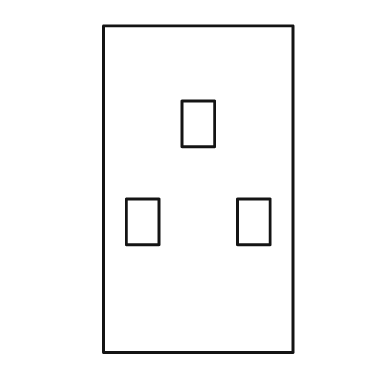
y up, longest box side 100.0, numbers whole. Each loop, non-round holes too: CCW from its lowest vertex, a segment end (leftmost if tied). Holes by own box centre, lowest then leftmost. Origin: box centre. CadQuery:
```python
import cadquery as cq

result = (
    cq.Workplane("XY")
    .moveTo(-29.0, -50.0)
    .lineTo(29.0, -50.0)
    .lineTo(29.0, 50.0)
    .lineTo(-29.0, 50.0)
    .close()
    .moveTo(-22.0, -17.0)
    .lineTo(-12.0, -17.0)
    .lineTo(-12.0, -3.0)
    .lineTo(-22.0, -3.0)
    .close()
    .moveTo(12.0, -17.0)
    .lineTo(22.0, -17.0)
    .lineTo(22.0, -3.0)
    .lineTo(12.0, -3.0)
    .close()
    .moveTo(-5.0, 13.0)
    .lineTo(5.0, 13.0)
    .lineTo(5.0, 27.0)
    .lineTo(-5.0, 27.0)
    .close()
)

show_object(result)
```